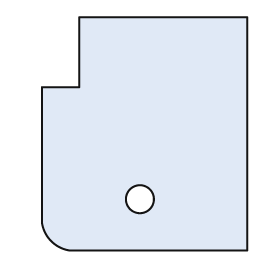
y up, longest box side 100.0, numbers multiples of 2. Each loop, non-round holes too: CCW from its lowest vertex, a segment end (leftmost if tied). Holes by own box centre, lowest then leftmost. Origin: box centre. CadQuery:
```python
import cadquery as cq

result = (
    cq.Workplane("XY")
    .moveTo(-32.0, -50.0)
    .lineTo(44.0, -50.0)
    .lineTo(44.0, 50.0)
    .lineTo(-28.0, 50.0)
    .lineTo(-28.0, 20.0)
    .lineTo(-44.0, 20.0)
    .lineTo(-44.0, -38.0)
    .threePointArc((-40.0, -46.0), (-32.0, -50.0))
    .close()
    .moveTo(-2.0, -28.0)
    .circle(6.0)
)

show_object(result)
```